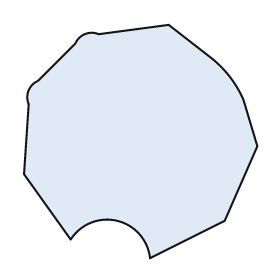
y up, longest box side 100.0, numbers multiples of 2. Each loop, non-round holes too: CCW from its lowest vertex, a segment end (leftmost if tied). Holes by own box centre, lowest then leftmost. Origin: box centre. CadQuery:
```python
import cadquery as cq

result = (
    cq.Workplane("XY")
    .moveTo(4.0, -50.0)
    .lineTo(36.0, -34.0)
    .lineTo(50.0, -2.0)
    .lineTo(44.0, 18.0)
    .threePointArc((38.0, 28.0), (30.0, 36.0))
    .lineTo(12.0, 50.0)
    .lineTo(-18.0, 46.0)
    .threePointArc((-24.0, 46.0), (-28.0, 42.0))
    .lineTo(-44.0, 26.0)
    .threePointArc((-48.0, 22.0), (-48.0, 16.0))
    .lineTo(-50.0, -14.0)
    .lineTo(-30.0, -42.0)
    .threePointArc((-10.0, -34.0), (4.0, -50.0))
    .close()
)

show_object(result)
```